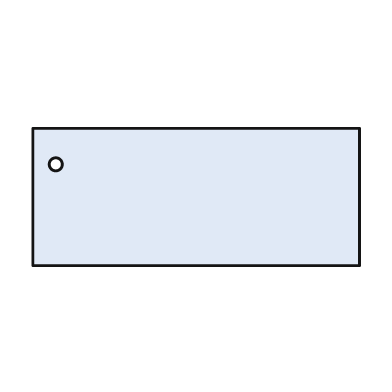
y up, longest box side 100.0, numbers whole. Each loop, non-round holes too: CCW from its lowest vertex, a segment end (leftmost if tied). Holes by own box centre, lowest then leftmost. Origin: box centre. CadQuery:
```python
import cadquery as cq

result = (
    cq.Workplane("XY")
    .moveTo(-50.0, -21.0)
    .lineTo(50.0, -21.0)
    .lineTo(50.0, 21.0)
    .lineTo(-50.0, 21.0)
    .close()
    .moveTo(-43.0, 10.0)
    .circle(2.0)
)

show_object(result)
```